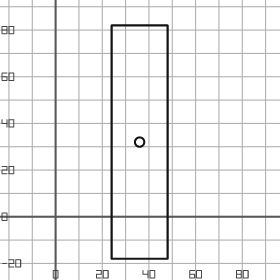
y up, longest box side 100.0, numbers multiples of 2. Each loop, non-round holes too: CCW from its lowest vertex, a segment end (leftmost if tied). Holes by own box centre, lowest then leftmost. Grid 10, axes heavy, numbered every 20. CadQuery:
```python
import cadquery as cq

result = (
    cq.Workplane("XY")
    .moveTo(24.0, -18.0)
    .lineTo(48.0, -18.0)
    .lineTo(48.0, 82.0)
    .lineTo(24.0, 82.0)
    .close()
    .moveTo(36.0, 32.0)
    .circle(2.0)
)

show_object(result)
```